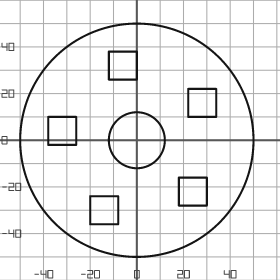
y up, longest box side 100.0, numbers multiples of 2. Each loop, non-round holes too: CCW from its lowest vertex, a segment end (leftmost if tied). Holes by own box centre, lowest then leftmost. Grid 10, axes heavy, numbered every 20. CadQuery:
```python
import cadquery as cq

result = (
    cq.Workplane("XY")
    .moveTo(0.0, 0.0)
    .circle(50.0)
    .moveTo(-20.0, -36.0)
    .lineTo(-8.0, -36.0)
    .lineTo(-8.0, -24.0)
    .lineTo(-20.0, -24.0)
    .close()
    .moveTo(18.0, -28.0)
    .lineTo(30.0, -28.0)
    .lineTo(30.0, -16.0)
    .lineTo(18.0, -16.0)
    .close()
    .moveTo(0.0, 0.0)
    .circle(12.0)
    .moveTo(-38.0, -2.0)
    .lineTo(-26.0, -2.0)
    .lineTo(-26.0, 10.0)
    .lineTo(-38.0, 10.0)
    .close()
    .moveTo(22.0, 10.0)
    .lineTo(34.0, 10.0)
    .lineTo(34.0, 22.0)
    .lineTo(22.0, 22.0)
    .close()
    .moveTo(-12.0, 26.0)
    .lineTo(0.0, 26.0)
    .lineTo(0.0, 38.0)
    .lineTo(-12.0, 38.0)
    .close()
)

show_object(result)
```